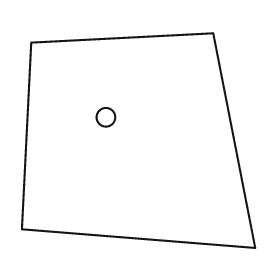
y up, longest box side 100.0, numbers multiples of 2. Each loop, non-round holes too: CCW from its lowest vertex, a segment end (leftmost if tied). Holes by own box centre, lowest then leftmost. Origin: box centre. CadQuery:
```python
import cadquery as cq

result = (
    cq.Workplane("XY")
    .moveTo(50.0, -46.0)
    .lineTo(32.0, 46.0)
    .lineTo(-46.0, 42.0)
    .lineTo(-50.0, -38.0)
    .close()
    .moveTo(-14.0, 10.0)
    .circle(4.0)
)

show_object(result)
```